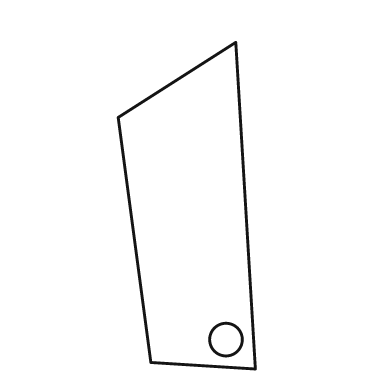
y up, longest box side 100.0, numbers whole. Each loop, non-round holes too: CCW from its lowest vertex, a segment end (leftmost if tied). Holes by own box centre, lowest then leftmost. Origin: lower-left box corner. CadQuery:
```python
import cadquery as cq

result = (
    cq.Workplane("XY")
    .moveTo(42.0, 0.0)
    .lineTo(36.0, 100.0)
    .lineTo(0.0, 77.0)
    .lineTo(10.0, 2.0)
    .close()
    .moveTo(33.0, 9.0)
    .circle(5.0)
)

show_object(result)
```